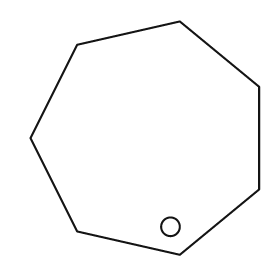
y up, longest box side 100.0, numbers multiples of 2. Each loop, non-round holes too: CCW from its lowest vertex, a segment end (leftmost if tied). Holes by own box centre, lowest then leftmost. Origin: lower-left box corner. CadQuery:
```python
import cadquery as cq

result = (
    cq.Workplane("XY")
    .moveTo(64.0, 0.0)
    .lineTo(98.0, 28.0)
    .lineTo(98.0, 72.0)
    .lineTo(64.0, 100.0)
    .lineTo(20.0, 90.0)
    .lineTo(0.0, 50.0)
    .lineTo(20.0, 10.0)
    .close()
    .moveTo(60.0, 12.0)
    .circle(4.0)
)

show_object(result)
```